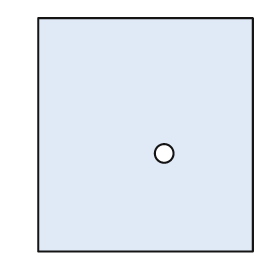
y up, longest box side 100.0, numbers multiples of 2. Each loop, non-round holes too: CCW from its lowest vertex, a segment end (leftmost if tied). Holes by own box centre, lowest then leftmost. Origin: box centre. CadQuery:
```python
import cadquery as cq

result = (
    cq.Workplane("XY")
    .moveTo(-46.0, -50.0)
    .lineTo(46.0, -50.0)
    .lineTo(46.0, 50.0)
    .lineTo(-46.0, 50.0)
    .close()
    .moveTo(8.0, -8.0)
    .circle(4.0)
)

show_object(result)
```